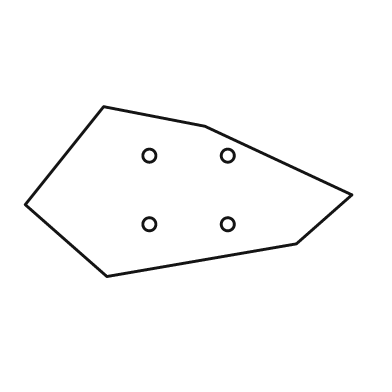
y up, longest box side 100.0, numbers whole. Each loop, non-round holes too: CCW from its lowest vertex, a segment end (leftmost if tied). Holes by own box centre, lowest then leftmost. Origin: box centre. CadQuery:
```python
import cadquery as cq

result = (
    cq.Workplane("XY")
    .moveTo(-25.0, -26.0)
    .lineTo(33.0, -16.0)
    .lineTo(50.0, -1.0)
    .lineTo(5.0, 20.0)
    .lineTo(-26.0, 26.0)
    .lineTo(-50.0, -4.0)
    .close()
    .moveTo(-12.0, -10.0)
    .circle(2.0)
    .moveTo(12.0, -10.0)
    .circle(2.0)
    .moveTo(-12.0, 11.0)
    .circle(2.0)
    .moveTo(12.0, 11.0)
    .circle(2.0)
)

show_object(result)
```